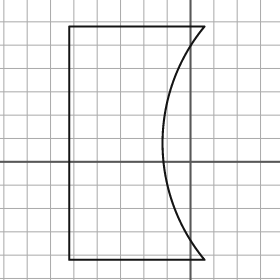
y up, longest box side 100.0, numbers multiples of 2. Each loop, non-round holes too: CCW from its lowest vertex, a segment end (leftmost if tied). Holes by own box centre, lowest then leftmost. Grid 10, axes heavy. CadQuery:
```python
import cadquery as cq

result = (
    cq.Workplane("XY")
    .moveTo(-52.0, -42.0)
    .lineTo(6.0, -42.0)
    .threePointArc((-12.0, 8.0), (6.0, 58.0))
    .lineTo(-52.0, 58.0)
    .close()
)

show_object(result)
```